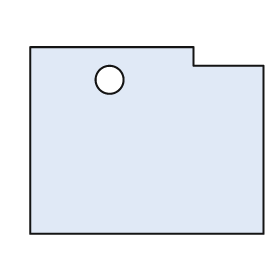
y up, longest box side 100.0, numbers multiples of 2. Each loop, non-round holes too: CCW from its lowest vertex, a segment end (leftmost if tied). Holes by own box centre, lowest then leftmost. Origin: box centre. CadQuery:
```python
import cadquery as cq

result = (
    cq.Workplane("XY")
    .moveTo(-50.0, -40.0)
    .lineTo(50.0, -40.0)
    .lineTo(50.0, 32.0)
    .lineTo(20.0, 32.0)
    .lineTo(20.0, 40.0)
    .lineTo(-50.0, 40.0)
    .close()
    .moveTo(-16.0, 26.0)
    .circle(6.0)
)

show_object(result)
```